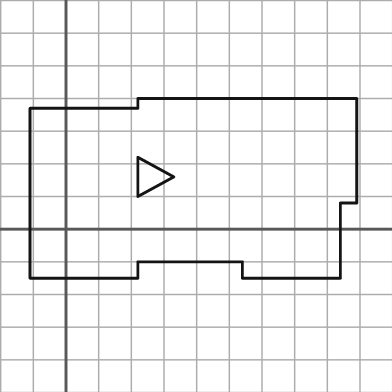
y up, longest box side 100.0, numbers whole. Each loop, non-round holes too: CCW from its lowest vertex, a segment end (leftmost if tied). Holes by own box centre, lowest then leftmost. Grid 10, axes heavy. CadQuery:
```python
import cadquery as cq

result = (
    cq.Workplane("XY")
    .moveTo(-11.0, -15.0)
    .lineTo(22.0, -15.0)
    .lineTo(22.0, -10.0)
    .lineTo(54.0, -10.0)
    .lineTo(54.0, -15.0)
    .lineTo(84.0, -15.0)
    .lineTo(84.0, 8.0)
    .lineTo(89.0, 8.0)
    .lineTo(89.0, 40.0)
    .lineTo(22.0, 40.0)
    .lineTo(22.0, 37.0)
    .lineTo(-11.0, 37.0)
    .close()
    .moveTo(22.0, 10.0)
    .lineTo(33.0, 16.0)
    .lineTo(22.0, 22.0)
    .close()
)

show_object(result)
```